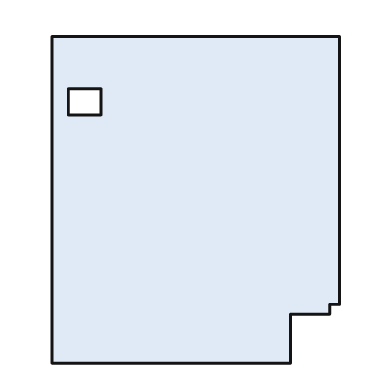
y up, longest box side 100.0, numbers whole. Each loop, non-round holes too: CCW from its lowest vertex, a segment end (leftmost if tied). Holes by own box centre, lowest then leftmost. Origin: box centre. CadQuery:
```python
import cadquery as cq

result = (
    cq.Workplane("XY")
    .moveTo(-44.0, -50.0)
    .lineTo(29.0, -50.0)
    .lineTo(29.0, -35.0)
    .lineTo(41.0, -35.0)
    .lineTo(41.0, -32.0)
    .lineTo(44.0, -32.0)
    .lineTo(44.0, 50.0)
    .lineTo(-44.0, 50.0)
    .close()
    .moveTo(-39.0, 26.0)
    .lineTo(-29.0, 26.0)
    .lineTo(-29.0, 34.0)
    .lineTo(-39.0, 34.0)
    .close()
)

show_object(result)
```